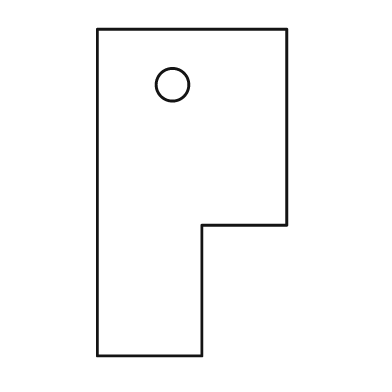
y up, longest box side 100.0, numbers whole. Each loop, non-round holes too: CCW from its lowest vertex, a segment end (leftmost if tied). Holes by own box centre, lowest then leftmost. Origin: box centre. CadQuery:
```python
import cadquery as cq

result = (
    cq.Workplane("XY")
    .moveTo(-29.0, -50.0)
    .lineTo(3.0, -50.0)
    .lineTo(3.0, -10.0)
    .lineTo(29.0, -10.0)
    .lineTo(29.0, 50.0)
    .lineTo(-29.0, 50.0)
    .close()
    .moveTo(-6.0, 33.0)
    .circle(5.0)
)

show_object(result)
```